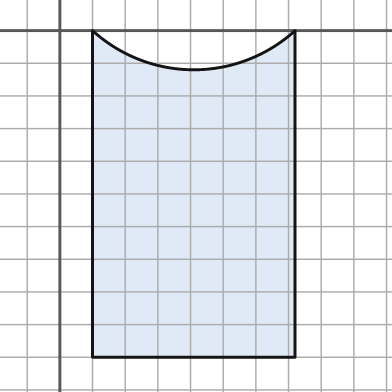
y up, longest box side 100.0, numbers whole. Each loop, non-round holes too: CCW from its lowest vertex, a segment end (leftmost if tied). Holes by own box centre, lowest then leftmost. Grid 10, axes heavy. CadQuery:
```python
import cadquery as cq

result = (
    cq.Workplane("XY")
    .moveTo(10.0, -100.0)
    .lineTo(72.0, -100.0)
    .lineTo(72.0, 0.0)
    .threePointArc((41.0, -12.0), (10.0, 0.0))
    .close()
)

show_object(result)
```